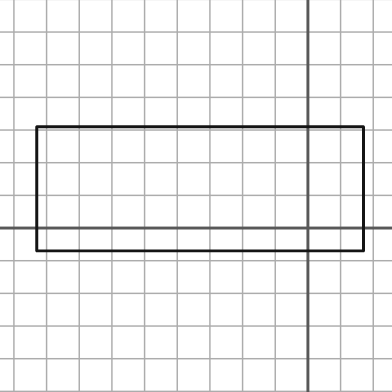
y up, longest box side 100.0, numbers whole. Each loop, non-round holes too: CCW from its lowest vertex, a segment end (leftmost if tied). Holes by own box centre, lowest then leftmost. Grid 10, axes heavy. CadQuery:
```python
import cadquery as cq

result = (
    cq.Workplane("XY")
    .moveTo(-83.0, -7.0)
    .lineTo(17.0, -7.0)
    .lineTo(17.0, 31.0)
    .lineTo(-83.0, 31.0)
    .close()
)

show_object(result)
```